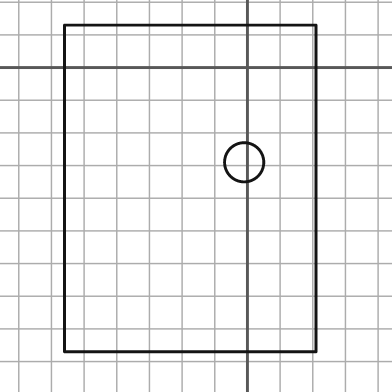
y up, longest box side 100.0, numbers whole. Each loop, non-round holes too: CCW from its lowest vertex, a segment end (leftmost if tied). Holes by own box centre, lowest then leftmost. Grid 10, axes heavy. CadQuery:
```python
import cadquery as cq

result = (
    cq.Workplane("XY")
    .moveTo(-56.0, -87.0)
    .lineTo(21.0, -87.0)
    .lineTo(21.0, 13.0)
    .lineTo(-56.0, 13.0)
    .close()
    .moveTo(-1.0, -29.0)
    .circle(6.0)
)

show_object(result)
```